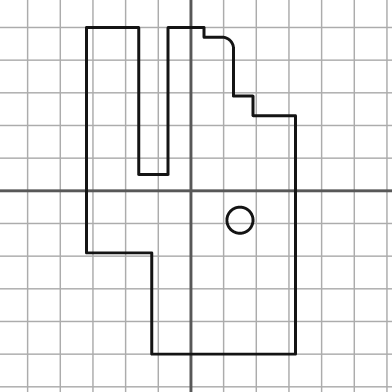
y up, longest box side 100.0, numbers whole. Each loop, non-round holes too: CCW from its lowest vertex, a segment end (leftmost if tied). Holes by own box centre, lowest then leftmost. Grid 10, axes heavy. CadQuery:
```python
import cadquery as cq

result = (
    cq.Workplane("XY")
    .moveTo(-12.0, -50.0)
    .lineTo(32.0, -50.0)
    .lineTo(32.0, 23.0)
    .lineTo(19.0, 23.0)
    .lineTo(19.0, 29.0)
    .lineTo(13.0, 29.0)
    .lineTo(13.0, 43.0)
    .threePointArc((12.0, 46.0), (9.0, 47.0))
    .lineTo(4.0, 47.0)
    .lineTo(4.0, 50.0)
    .lineTo(-7.0, 50.0)
    .lineTo(-7.0, 5.0)
    .lineTo(-16.0, 5.0)
    .lineTo(-16.0, 50.0)
    .lineTo(-32.0, 50.0)
    .lineTo(-32.0, -19.0)
    .lineTo(-12.0, -19.0)
    .close()
    .moveTo(15.0, -9.0)
    .circle(4.0)
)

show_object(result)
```